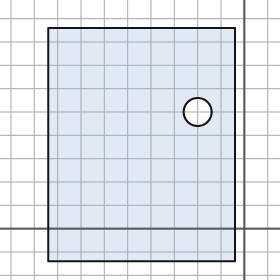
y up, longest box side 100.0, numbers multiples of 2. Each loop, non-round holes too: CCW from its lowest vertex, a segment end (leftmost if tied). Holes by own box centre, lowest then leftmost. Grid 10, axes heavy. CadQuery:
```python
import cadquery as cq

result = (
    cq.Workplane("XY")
    .moveTo(-84.0, -14.0)
    .lineTo(-4.0, -14.0)
    .lineTo(-4.0, 86.0)
    .lineTo(-84.0, 86.0)
    .close()
    .moveTo(-20.0, 50.0)
    .circle(6.0)
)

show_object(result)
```